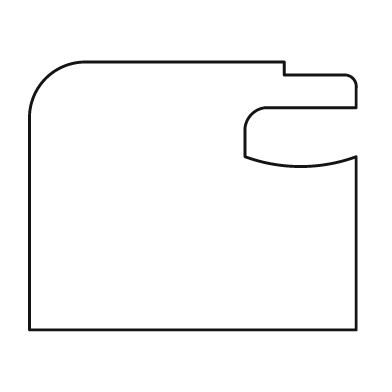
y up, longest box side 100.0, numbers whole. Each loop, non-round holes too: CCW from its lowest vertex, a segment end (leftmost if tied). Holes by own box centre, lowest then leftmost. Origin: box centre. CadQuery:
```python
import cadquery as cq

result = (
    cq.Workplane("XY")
    .moveTo(-50.0, -41.0)
    .lineTo(50.0, -41.0)
    .lineTo(50.0, 12.0)
    .threePointArc((33.0, 9.0), (16.0, 12.0))
    .lineTo(16.0, 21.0)
    .threePointArc((18.0, 25.0), (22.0, 27.0))
    .lineTo(50.0, 27.0)
    .lineTo(50.0, 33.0)
    .threePointArc((49.0, 36.0), (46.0, 37.0))
    .lineTo(28.0, 37.0)
    .lineTo(28.0, 41.0)
    .lineTo(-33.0, 41.0)
    .threePointArc((-45.0, 36.0), (-50.0, 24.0))
    .close()
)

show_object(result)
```